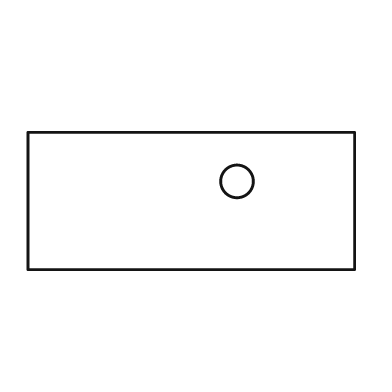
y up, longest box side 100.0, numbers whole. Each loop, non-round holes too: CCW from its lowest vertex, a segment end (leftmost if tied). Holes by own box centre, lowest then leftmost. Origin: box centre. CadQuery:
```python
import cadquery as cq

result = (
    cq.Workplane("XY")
    .moveTo(-50.0, -21.0)
    .lineTo(50.0, -21.0)
    .lineTo(50.0, 21.0)
    .lineTo(-50.0, 21.0)
    .close()
    .moveTo(14.0, 6.0)
    .circle(5.0)
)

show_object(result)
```